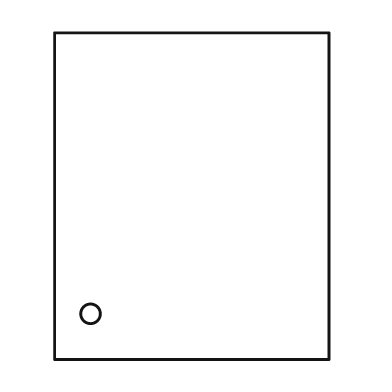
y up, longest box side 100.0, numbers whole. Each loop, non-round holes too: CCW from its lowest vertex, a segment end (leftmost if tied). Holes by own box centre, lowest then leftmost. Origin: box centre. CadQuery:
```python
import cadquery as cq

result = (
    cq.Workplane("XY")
    .moveTo(-42.0, -50.0)
    .lineTo(42.0, -50.0)
    .lineTo(42.0, 50.0)
    .lineTo(-42.0, 50.0)
    .close()
    .moveTo(-31.0, -36.0)
    .circle(3.0)
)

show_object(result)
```